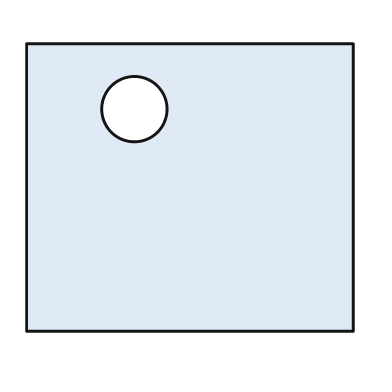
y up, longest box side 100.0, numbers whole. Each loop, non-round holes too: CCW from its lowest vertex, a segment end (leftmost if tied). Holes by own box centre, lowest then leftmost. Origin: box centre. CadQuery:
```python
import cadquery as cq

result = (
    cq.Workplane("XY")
    .moveTo(-50.0, -44.0)
    .lineTo(50.0, -44.0)
    .lineTo(50.0, 44.0)
    .lineTo(-50.0, 44.0)
    .close()
    .moveTo(-17.0, 24.0)
    .circle(10.0)
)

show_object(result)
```